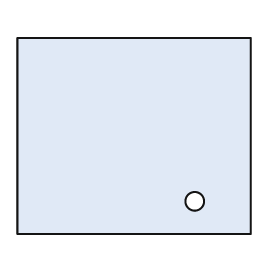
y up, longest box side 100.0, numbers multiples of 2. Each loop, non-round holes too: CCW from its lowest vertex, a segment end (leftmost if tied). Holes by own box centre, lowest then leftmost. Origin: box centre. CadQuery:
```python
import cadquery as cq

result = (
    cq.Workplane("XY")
    .moveTo(-50.0, -42.0)
    .lineTo(50.0, -42.0)
    .lineTo(50.0, 42.0)
    .lineTo(-50.0, 42.0)
    .close()
    .moveTo(26.0, -28.0)
    .circle(4.0)
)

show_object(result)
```